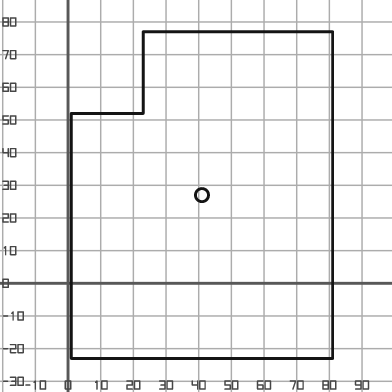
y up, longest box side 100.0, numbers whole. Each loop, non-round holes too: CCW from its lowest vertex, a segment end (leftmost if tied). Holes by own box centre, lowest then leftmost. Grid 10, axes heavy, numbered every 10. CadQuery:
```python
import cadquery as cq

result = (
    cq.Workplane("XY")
    .moveTo(1.0, -23.0)
    .lineTo(81.0, -23.0)
    .lineTo(81.0, 77.0)
    .lineTo(23.0, 77.0)
    .lineTo(23.0, 52.0)
    .lineTo(1.0, 52.0)
    .close()
    .moveTo(41.0, 27.0)
    .circle(2.0)
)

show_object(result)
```